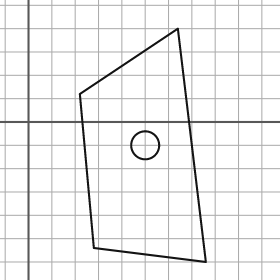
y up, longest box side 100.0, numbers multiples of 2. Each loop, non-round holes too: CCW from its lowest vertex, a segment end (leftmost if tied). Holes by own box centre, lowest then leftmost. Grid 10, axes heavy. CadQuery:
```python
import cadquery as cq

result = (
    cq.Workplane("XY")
    .moveTo(76.0, -60.0)
    .lineTo(64.0, 40.0)
    .lineTo(22.0, 12.0)
    .lineTo(28.0, -54.0)
    .close()
    .moveTo(50.0, -10.0)
    .circle(6.0)
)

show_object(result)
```